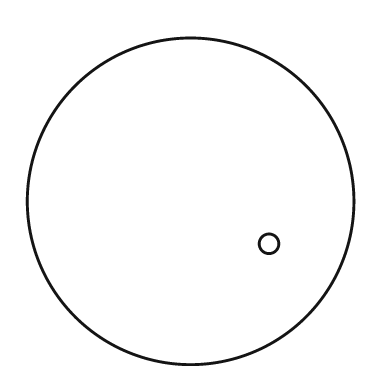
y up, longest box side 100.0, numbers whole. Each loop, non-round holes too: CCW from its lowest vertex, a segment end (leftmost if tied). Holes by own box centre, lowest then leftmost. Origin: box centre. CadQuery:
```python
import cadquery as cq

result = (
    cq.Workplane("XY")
    .moveTo(0.0, 0.0)
    .circle(50.0)
    .moveTo(24.0, -13.0)
    .circle(3.0)
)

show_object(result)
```